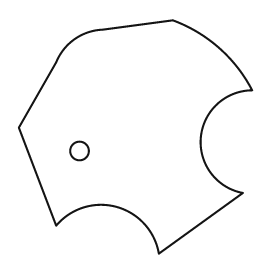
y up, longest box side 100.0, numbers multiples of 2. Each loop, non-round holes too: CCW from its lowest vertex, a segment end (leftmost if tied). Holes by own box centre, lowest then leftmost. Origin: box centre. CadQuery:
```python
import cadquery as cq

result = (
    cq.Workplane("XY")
    .moveTo(10.0, -50.0)
    .lineTo(46.0, -24.0)
    .threePointArc((28.0, 0.0), (50.0, 20.0))
    .threePointArc((36.0, 38.0), (16.0, 50.0))
    .lineTo(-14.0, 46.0)
    .threePointArc((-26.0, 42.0), (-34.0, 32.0))
    .lineTo(-50.0, 4.0)
    .lineTo(-34.0, -38.0)
    .threePointArc((-8.0, -30.0), (10.0, -50.0))
    .close()
    .moveTo(-24.0, -6.0)
    .circle(4.0)
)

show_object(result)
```